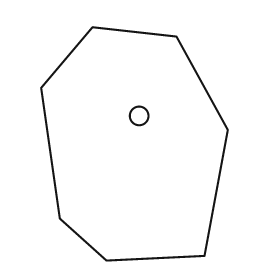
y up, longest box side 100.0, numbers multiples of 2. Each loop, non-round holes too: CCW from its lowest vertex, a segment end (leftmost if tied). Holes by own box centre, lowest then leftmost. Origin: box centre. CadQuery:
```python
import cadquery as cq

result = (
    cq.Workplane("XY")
    .moveTo(-12.0, -50.0)
    .lineTo(30.0, -48.0)
    .lineTo(40.0, 6.0)
    .lineTo(18.0, 46.0)
    .lineTo(-18.0, 50.0)
    .lineTo(-40.0, 24.0)
    .lineTo(-32.0, -32.0)
    .close()
    .moveTo(2.0, 12.0)
    .circle(4.0)
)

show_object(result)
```